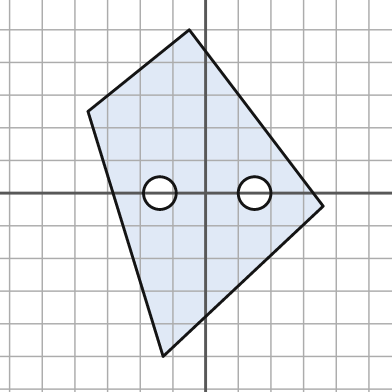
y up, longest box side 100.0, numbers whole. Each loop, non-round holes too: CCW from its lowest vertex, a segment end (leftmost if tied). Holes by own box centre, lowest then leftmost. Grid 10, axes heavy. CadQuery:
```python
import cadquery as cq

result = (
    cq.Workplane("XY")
    .moveTo(-13.0, -50.0)
    .lineTo(36.0, -4.0)
    .lineTo(-5.0, 50.0)
    .lineTo(-36.0, 25.0)
    .close()
    .moveTo(-14.0, 0.0)
    .circle(5.0)
    .moveTo(15.0, 0.0)
    .circle(5.0)
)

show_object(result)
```